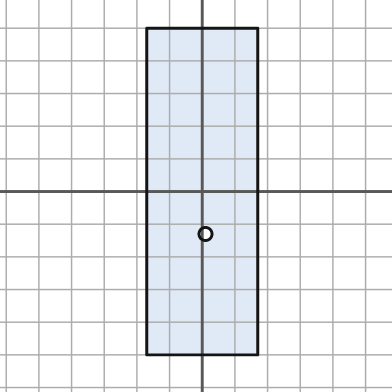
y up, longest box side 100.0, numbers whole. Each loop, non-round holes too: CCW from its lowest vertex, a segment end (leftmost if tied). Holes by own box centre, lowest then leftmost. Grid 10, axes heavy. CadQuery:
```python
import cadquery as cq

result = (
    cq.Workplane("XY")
    .moveTo(-17.0, -50.0)
    .lineTo(17.0, -50.0)
    .lineTo(17.0, 50.0)
    .lineTo(-17.0, 50.0)
    .close()
    .moveTo(1.0, -13.0)
    .circle(2.0)
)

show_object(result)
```